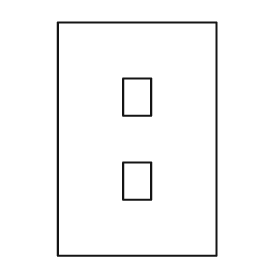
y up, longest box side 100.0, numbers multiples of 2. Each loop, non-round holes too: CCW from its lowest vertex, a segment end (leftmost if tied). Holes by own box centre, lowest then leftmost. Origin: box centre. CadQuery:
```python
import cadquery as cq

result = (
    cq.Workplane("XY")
    .moveTo(-34.0, -50.0)
    .lineTo(34.0, -50.0)
    .lineTo(34.0, 50.0)
    .lineTo(-34.0, 50.0)
    .close()
    .moveTo(-6.0, -26.0)
    .lineTo(6.0, -26.0)
    .lineTo(6.0, -10.0)
    .lineTo(-6.0, -10.0)
    .close()
    .moveTo(-6.0, 10.0)
    .lineTo(6.0, 10.0)
    .lineTo(6.0, 26.0)
    .lineTo(-6.0, 26.0)
    .close()
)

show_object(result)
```